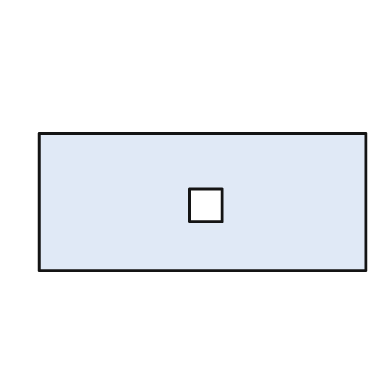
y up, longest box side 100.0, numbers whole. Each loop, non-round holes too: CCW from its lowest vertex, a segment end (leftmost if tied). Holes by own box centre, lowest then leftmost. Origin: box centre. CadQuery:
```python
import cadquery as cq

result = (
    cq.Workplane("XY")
    .moveTo(-50.0, -21.0)
    .lineTo(50.0, -21.0)
    .lineTo(50.0, 21.0)
    .lineTo(-50.0, 21.0)
    .close()
    .moveTo(-4.0, -6.0)
    .lineTo(6.0, -6.0)
    .lineTo(6.0, 4.0)
    .lineTo(-4.0, 4.0)
    .close()
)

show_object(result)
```